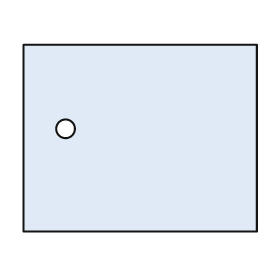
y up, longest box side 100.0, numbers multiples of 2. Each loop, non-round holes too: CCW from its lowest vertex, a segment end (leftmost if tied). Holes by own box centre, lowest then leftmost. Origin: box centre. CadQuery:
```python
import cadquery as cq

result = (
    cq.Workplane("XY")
    .moveTo(-50.0, -40.0)
    .lineTo(50.0, -40.0)
    .lineTo(50.0, 40.0)
    .lineTo(-50.0, 40.0)
    .close()
    .moveTo(-32.0, 4.0)
    .circle(4.0)
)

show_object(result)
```